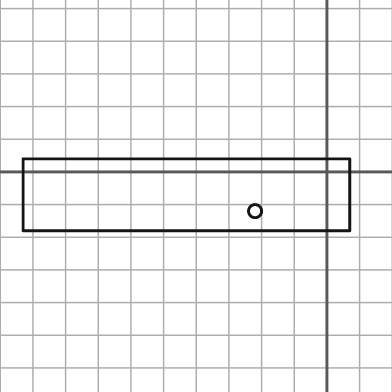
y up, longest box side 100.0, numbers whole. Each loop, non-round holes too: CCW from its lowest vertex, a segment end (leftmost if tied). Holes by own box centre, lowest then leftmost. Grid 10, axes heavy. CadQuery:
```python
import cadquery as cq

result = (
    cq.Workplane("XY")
    .moveTo(-93.0, -18.0)
    .lineTo(7.0, -18.0)
    .lineTo(7.0, 4.0)
    .lineTo(-93.0, 4.0)
    .close()
    .moveTo(-22.0, -12.0)
    .circle(2.0)
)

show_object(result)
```